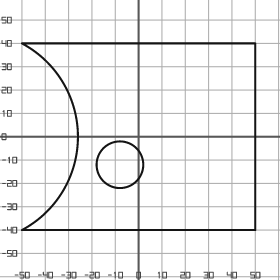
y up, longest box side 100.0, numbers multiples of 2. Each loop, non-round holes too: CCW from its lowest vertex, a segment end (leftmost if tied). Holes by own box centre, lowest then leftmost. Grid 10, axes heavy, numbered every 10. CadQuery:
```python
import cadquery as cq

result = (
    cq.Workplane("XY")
    .moveTo(-50.0, -40.0)
    .lineTo(50.0, -40.0)
    .lineTo(50.0, 40.0)
    .lineTo(-50.0, 40.0)
    .threePointArc((-26.0, 0.0), (-50.0, -40.0))
    .close()
    .moveTo(-8.0, -12.0)
    .circle(10.0)
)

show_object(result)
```